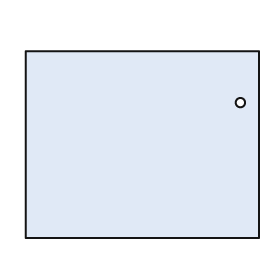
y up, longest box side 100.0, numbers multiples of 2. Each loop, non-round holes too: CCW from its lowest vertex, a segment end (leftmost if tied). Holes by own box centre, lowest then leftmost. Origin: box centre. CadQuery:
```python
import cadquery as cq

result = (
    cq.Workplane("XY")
    .moveTo(-50.0, -40.0)
    .lineTo(50.0, -40.0)
    .lineTo(50.0, 40.0)
    .lineTo(-50.0, 40.0)
    .close()
    .moveTo(42.0, 18.0)
    .circle(2.0)
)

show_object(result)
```